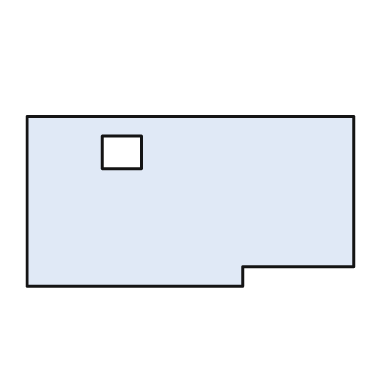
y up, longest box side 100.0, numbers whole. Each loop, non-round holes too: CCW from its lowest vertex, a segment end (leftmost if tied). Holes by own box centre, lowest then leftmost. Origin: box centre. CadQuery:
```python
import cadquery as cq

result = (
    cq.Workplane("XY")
    .moveTo(-50.0, -26.0)
    .lineTo(16.0, -26.0)
    .lineTo(16.0, -20.0)
    .lineTo(50.0, -20.0)
    .lineTo(50.0, 26.0)
    .lineTo(-50.0, 26.0)
    .close()
    .moveTo(-27.0, 10.0)
    .lineTo(-15.0, 10.0)
    .lineTo(-15.0, 20.0)
    .lineTo(-27.0, 20.0)
    .close()
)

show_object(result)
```